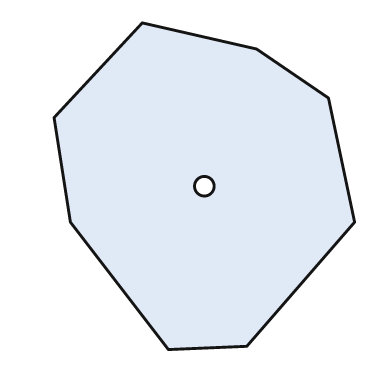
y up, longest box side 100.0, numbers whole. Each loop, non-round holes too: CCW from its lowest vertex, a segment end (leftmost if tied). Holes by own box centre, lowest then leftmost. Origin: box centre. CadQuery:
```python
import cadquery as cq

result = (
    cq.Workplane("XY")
    .moveTo(-11.0, -50.0)
    .lineTo(13.0, -49.0)
    .lineTo(46.0, -11.0)
    .lineTo(38.0, 27.0)
    .lineTo(16.0, 42.0)
    .lineTo(-19.0, 50.0)
    .lineTo(-46.0, 21.0)
    .lineTo(-41.0, -11.0)
    .close()
    .moveTo(0.0, 0.0)
    .circle(3.0)
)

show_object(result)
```